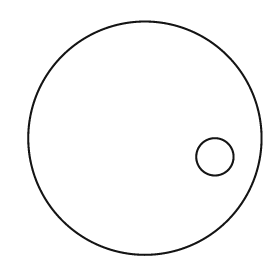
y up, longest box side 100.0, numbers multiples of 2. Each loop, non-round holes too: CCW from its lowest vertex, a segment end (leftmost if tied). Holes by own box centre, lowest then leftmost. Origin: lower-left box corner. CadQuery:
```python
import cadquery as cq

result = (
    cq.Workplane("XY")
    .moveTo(50.0, 50.0)
    .circle(50.0)
    .moveTo(80.0, 42.0)
    .circle(8.0)
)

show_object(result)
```